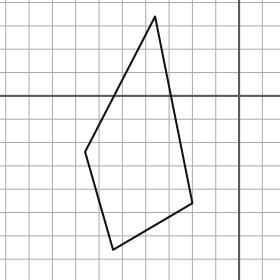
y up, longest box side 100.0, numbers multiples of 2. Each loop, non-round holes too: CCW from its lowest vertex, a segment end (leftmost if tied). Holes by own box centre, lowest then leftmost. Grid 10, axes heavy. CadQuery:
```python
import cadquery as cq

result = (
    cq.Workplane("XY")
    .moveTo(-54.0, -66.0)
    .lineTo(-20.0, -46.0)
    .lineTo(-36.0, 34.0)
    .lineTo(-66.0, -24.0)
    .close()
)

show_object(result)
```